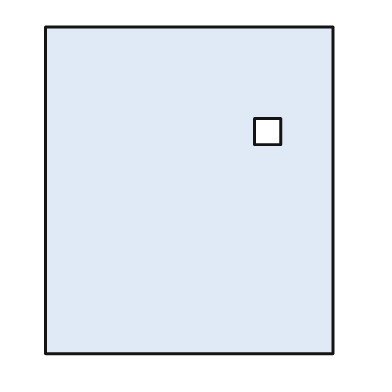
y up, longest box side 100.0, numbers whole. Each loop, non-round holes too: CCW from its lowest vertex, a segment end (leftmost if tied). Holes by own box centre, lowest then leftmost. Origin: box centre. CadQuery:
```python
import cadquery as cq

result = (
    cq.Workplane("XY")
    .moveTo(-44.0, -50.0)
    .lineTo(44.0, -50.0)
    .lineTo(44.0, 50.0)
    .lineTo(-44.0, 50.0)
    .close()
    .moveTo(20.0, 14.0)
    .lineTo(28.0, 14.0)
    .lineTo(28.0, 22.0)
    .lineTo(20.0, 22.0)
    .close()
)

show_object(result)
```